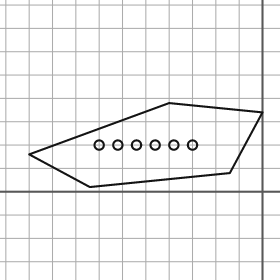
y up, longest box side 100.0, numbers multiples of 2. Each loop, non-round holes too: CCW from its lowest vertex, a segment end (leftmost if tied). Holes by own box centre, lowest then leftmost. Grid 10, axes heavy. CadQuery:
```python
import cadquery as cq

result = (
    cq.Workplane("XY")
    .moveTo(-74.0, 2.0)
    .lineTo(-14.0, 8.0)
    .lineTo(0.0, 34.0)
    .lineTo(-40.0, 38.0)
    .lineTo(-100.0, 16.0)
    .close()
    .moveTo(-70.0, 20.0)
    .circle(2.0)
    .moveTo(-62.0, 20.0)
    .circle(2.0)
    .moveTo(-54.0, 20.0)
    .circle(2.0)
    .moveTo(-46.0, 20.0)
    .circle(2.0)
    .moveTo(-38.0, 20.0)
    .circle(2.0)
    .moveTo(-30.0, 20.0)
    .circle(2.0)
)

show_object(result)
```